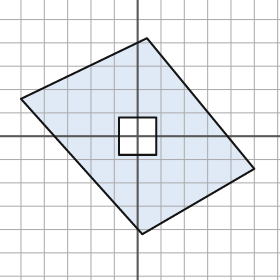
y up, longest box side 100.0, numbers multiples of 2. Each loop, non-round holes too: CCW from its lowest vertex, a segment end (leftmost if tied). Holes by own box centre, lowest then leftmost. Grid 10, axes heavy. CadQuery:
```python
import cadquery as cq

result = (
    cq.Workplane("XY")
    .moveTo(2.0, -42.0)
    .lineTo(50.0, -14.0)
    .lineTo(4.0, 42.0)
    .lineTo(-50.0, 16.0)
    .close()
    .moveTo(-8.0, -8.0)
    .lineTo(8.0, -8.0)
    .lineTo(8.0, 8.0)
    .lineTo(-8.0, 8.0)
    .close()
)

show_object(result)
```